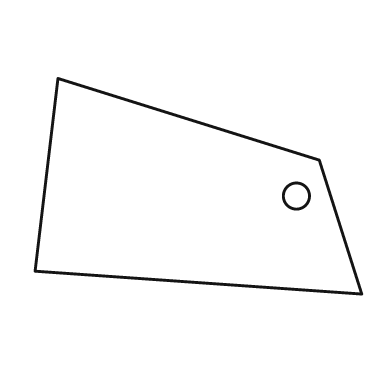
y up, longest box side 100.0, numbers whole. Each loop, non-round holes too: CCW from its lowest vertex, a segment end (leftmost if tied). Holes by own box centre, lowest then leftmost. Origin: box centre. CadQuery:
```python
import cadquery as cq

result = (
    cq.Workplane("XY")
    .moveTo(50.0, -33.0)
    .lineTo(37.0, 8.0)
    .lineTo(-43.0, 33.0)
    .lineTo(-50.0, -26.0)
    .close()
    .moveTo(30.0, -3.0)
    .circle(4.0)
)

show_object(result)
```